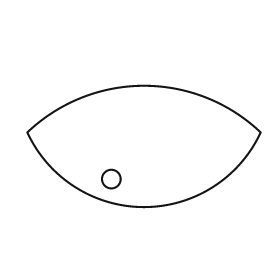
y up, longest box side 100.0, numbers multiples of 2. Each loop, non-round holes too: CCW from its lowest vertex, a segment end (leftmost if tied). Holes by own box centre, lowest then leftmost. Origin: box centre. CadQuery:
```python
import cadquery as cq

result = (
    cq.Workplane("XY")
    .moveTo(-50.0, 6.0)
    .threePointArc((0.0, -26.0), (50.0, 6.0))
    .threePointArc((0.0, 26.0), (-50.0, 6.0))
    .close()
    .moveTo(-14.0, -14.0)
    .circle(4.0)
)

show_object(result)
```